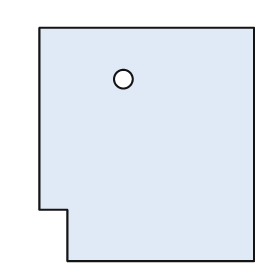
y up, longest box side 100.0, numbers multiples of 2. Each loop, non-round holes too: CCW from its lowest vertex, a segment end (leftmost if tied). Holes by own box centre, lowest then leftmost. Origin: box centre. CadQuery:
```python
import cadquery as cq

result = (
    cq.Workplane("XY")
    .moveTo(-34.0, -50.0)
    .lineTo(46.0, -50.0)
    .lineTo(46.0, 50.0)
    .lineTo(-46.0, 50.0)
    .lineTo(-46.0, -28.0)
    .lineTo(-34.0, -28.0)
    .close()
    .moveTo(-10.0, 28.0)
    .circle(4.0)
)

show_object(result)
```